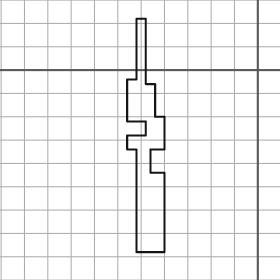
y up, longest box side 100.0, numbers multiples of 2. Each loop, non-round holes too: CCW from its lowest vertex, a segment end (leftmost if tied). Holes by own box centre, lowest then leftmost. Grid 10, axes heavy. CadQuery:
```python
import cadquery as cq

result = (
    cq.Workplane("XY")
    .moveTo(-52.0, -78.0)
    .lineTo(-40.0, -78.0)
    .lineTo(-40.0, -44.0)
    .lineTo(-46.0, -44.0)
    .lineTo(-46.0, -34.0)
    .lineTo(-40.0, -34.0)
    .lineTo(-40.0, -20.0)
    .lineTo(-44.0, -20.0)
    .lineTo(-44.0, -6.0)
    .lineTo(-48.0, -6.0)
    .lineTo(-48.0, 22.0)
    .lineTo(-52.0, 22.0)
    .lineTo(-52.0, -4.0)
    .lineTo(-56.0, -4.0)
    .lineTo(-56.0, -22.0)
    .lineTo(-48.0, -22.0)
    .lineTo(-48.0, -28.0)
    .lineTo(-56.0, -28.0)
    .lineTo(-56.0, -34.0)
    .lineTo(-52.0, -34.0)
    .close()
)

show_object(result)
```